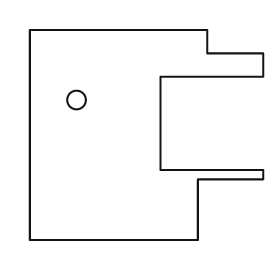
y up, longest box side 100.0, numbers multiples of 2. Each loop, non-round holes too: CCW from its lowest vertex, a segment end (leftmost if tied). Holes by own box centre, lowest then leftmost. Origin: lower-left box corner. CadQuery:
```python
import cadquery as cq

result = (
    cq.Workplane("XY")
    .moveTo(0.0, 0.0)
    .lineTo(72.0, 0.0)
    .lineTo(72.0, 26.0)
    .lineTo(100.0, 26.0)
    .lineTo(100.0, 30.0)
    .lineTo(56.0, 30.0)
    .lineTo(56.0, 70.0)
    .lineTo(100.0, 70.0)
    .lineTo(100.0, 80.0)
    .lineTo(76.0, 80.0)
    .lineTo(76.0, 90.0)
    .lineTo(0.0, 90.0)
    .close()
    .moveTo(20.0, 60.0)
    .circle(4.0)
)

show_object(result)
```